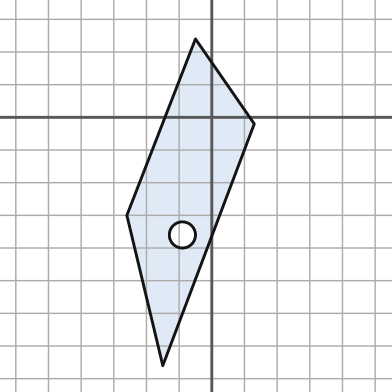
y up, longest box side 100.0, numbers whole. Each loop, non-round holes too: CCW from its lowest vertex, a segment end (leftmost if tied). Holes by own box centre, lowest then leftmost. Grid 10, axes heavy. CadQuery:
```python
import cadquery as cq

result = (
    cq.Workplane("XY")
    .moveTo(-15.0, -76.0)
    .lineTo(13.0, -2.0)
    .lineTo(-5.0, 24.0)
    .lineTo(-26.0, -30.0)
    .close()
    .moveTo(-9.0, -36.0)
    .circle(4.0)
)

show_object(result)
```